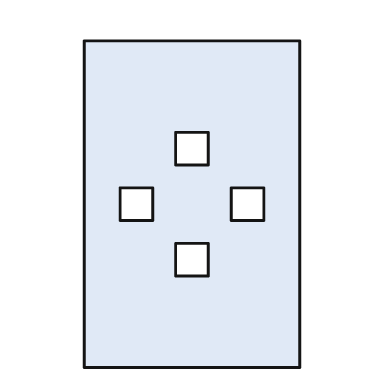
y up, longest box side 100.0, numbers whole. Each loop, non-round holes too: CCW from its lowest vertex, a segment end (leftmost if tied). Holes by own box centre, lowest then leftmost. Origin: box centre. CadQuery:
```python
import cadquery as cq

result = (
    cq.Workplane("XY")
    .moveTo(-33.0, -50.0)
    .lineTo(33.0, -50.0)
    .lineTo(33.0, 50.0)
    .lineTo(-33.0, 50.0)
    .close()
    .moveTo(-5.0, -22.0)
    .lineTo(5.0, -22.0)
    .lineTo(5.0, -12.0)
    .lineTo(-5.0, -12.0)
    .close()
    .moveTo(-22.0, -5.0)
    .lineTo(-12.0, -5.0)
    .lineTo(-12.0, 5.0)
    .lineTo(-22.0, 5.0)
    .close()
    .moveTo(12.0, -5.0)
    .lineTo(22.0, -5.0)
    .lineTo(22.0, 5.0)
    .lineTo(12.0, 5.0)
    .close()
    .moveTo(-5.0, 12.0)
    .lineTo(5.0, 12.0)
    .lineTo(5.0, 22.0)
    .lineTo(-5.0, 22.0)
    .close()
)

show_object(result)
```